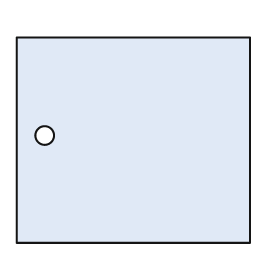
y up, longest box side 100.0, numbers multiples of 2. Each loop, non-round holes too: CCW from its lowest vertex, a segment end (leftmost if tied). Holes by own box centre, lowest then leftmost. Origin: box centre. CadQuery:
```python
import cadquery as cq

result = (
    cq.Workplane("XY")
    .moveTo(-50.0, -44.0)
    .lineTo(50.0, -44.0)
    .lineTo(50.0, 44.0)
    .lineTo(-50.0, 44.0)
    .close()
    .moveTo(-38.0, 2.0)
    .circle(4.0)
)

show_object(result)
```